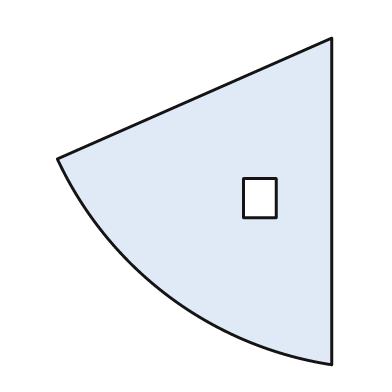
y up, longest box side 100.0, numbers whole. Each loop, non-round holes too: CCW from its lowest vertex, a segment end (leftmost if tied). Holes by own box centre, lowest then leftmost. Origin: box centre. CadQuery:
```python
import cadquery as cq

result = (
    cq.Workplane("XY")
    .moveTo(42.0, -50.0)
    .lineTo(42.0, 50.0)
    .lineTo(-42.0, 13.0)
    .threePointArc((-8.0, -29.0), (42.0, -50.0))
    .close()
    .moveTo(15.0, -5.0)
    .lineTo(25.0, -5.0)
    .lineTo(25.0, 7.0)
    .lineTo(15.0, 7.0)
    .close()
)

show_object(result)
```